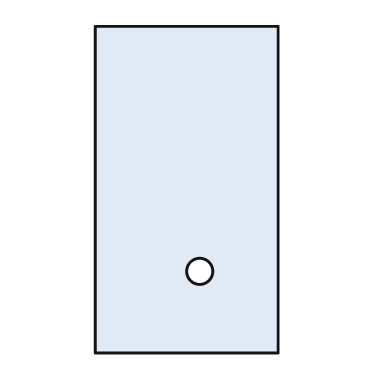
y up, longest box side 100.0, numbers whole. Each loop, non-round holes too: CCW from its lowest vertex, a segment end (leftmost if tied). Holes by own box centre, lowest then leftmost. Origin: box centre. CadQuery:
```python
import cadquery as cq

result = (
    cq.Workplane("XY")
    .moveTo(-28.0, -50.0)
    .lineTo(28.0, -50.0)
    .lineTo(28.0, 50.0)
    .lineTo(-28.0, 50.0)
    .close()
    .moveTo(4.0, -25.0)
    .circle(4.0)
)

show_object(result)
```